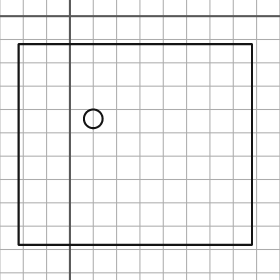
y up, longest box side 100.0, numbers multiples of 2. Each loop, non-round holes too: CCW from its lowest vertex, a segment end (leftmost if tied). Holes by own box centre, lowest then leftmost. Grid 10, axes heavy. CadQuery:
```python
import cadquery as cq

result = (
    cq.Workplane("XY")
    .moveTo(-22.0, -98.0)
    .lineTo(78.0, -98.0)
    .lineTo(78.0, -12.0)
    .lineTo(-22.0, -12.0)
    .close()
    .moveTo(10.0, -44.0)
    .circle(4.0)
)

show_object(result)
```